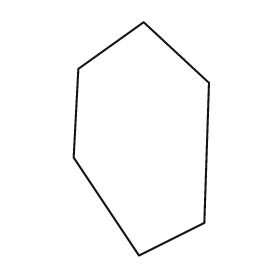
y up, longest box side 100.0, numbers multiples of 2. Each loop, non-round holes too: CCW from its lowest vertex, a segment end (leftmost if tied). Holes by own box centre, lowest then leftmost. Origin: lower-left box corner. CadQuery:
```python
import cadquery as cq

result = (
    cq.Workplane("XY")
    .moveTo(28.0, 0.0)
    .lineTo(56.0, 14.0)
    .lineTo(58.0, 74.0)
    .lineTo(30.0, 100.0)
    .lineTo(2.0, 80.0)
    .lineTo(0.0, 42.0)
    .close()
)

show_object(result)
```